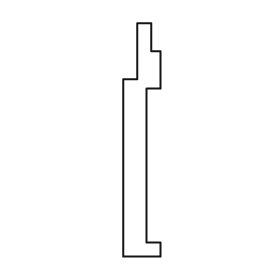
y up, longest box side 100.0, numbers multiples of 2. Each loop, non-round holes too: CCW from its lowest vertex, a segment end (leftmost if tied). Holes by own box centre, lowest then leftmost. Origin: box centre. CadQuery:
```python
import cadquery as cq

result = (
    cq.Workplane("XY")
    .moveTo(-8.0, -50.0)
    .lineTo(8.0, -50.0)
    .lineTo(8.0, -44.0)
    .lineTo(2.0, -44.0)
    .lineTo(2.0, 22.0)
    .lineTo(8.0, 22.0)
    .lineTo(8.0, 38.0)
    .lineTo(4.0, 38.0)
    .lineTo(4.0, 50.0)
    .lineTo(-2.0, 50.0)
    .lineTo(-2.0, 26.0)
    .lineTo(-8.0, 26.0)
    .close()
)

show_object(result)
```